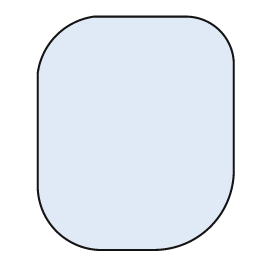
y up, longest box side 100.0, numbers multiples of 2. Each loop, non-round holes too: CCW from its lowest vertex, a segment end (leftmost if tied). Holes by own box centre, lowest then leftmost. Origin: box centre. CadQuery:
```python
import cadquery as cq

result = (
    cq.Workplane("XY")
    .moveTo(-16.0, -50.0)
    .lineTo(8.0, -50.0)
    .threePointArc((32.0, -40.0), (42.0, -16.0))
    .lineTo(42.0, 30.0)
    .threePointArc((36.0, 44.0), (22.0, 50.0))
    .lineTo(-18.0, 50.0)
    .threePointArc((-34.0, 42.0), (-42.0, 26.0))
    .lineTo(-42.0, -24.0)
    .threePointArc((-34.0, -42.0), (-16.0, -50.0))
    .close()
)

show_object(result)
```